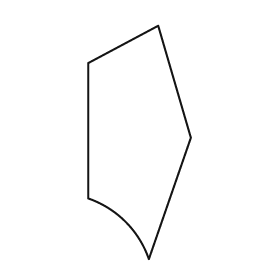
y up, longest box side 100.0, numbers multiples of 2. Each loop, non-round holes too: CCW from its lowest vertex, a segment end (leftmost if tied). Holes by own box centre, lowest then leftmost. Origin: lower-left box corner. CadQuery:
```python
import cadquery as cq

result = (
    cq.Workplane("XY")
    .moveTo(26.0, 0.0)
    .lineTo(44.0, 52.0)
    .lineTo(30.0, 100.0)
    .lineTo(0.0, 84.0)
    .lineTo(0.0, 26.0)
    .threePointArc((16.0, 16.0), (26.0, 0.0))
    .close()
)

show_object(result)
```